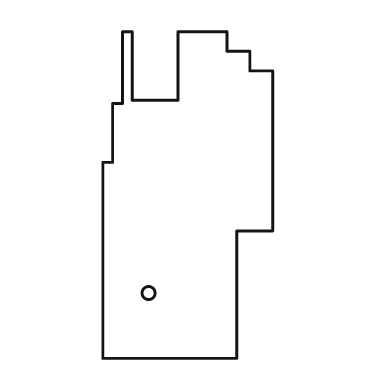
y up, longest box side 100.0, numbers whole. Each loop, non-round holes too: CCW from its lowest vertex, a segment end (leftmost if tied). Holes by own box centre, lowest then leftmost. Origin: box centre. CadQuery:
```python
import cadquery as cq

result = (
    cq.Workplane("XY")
    .moveTo(-26.0, -50.0)
    .lineTo(15.0, -50.0)
    .lineTo(15.0, -11.0)
    .lineTo(26.0, -11.0)
    .lineTo(26.0, 38.0)
    .lineTo(19.0, 38.0)
    .lineTo(19.0, 44.0)
    .lineTo(12.0, 44.0)
    .lineTo(12.0, 50.0)
    .lineTo(-3.0, 50.0)
    .lineTo(-3.0, 29.0)
    .lineTo(-17.0, 29.0)
    .lineTo(-17.0, 50.0)
    .lineTo(-20.0, 50.0)
    .lineTo(-20.0, 28.0)
    .lineTo(-23.0, 28.0)
    .lineTo(-23.0, 10.0)
    .lineTo(-26.0, 10.0)
    .close()
    .moveTo(-12.0, -30.0)
    .circle(2.0)
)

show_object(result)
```